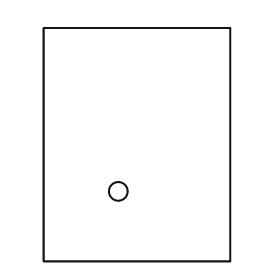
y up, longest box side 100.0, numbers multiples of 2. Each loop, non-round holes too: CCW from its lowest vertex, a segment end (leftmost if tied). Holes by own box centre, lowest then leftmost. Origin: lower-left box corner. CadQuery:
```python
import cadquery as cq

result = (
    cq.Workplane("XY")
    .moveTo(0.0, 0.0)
    .lineTo(80.0, 0.0)
    .lineTo(80.0, 100.0)
    .lineTo(0.0, 100.0)
    .close()
    .moveTo(32.0, 30.0)
    .circle(4.0)
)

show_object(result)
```